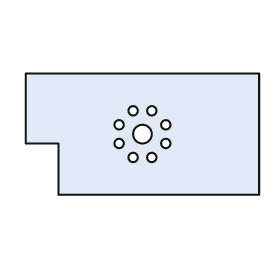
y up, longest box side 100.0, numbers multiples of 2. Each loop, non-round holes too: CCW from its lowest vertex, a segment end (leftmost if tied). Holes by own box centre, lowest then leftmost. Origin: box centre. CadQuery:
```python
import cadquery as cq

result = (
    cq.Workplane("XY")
    .moveTo(-36.0, -26.0)
    .lineTo(50.0, -26.0)
    .lineTo(50.0, 26.0)
    .lineTo(-50.0, 26.0)
    .lineTo(-50.0, -4.0)
    .lineTo(-36.0, -4.0)
    .close()
    .moveTo(-4.0, -10.0)
    .circle(2.0)
    .moveTo(4.0, -10.0)
    .circle(2.0)
    .moveTo(-10.0, -4.0)
    .circle(2.0)
    .moveTo(10.0, -4.0)
    .circle(2.0)
    .moveTo(0.0, 0.0)
    .circle(4.0)
    .moveTo(-10.0, 4.0)
    .circle(2.0)
    .moveTo(10.0, 4.0)
    .circle(2.0)
    .moveTo(-4.0, 10.0)
    .circle(2.0)
    .moveTo(4.0, 10.0)
    .circle(2.0)
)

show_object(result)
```